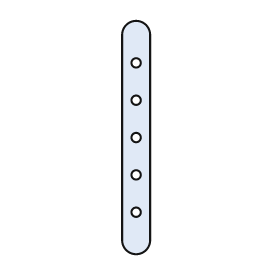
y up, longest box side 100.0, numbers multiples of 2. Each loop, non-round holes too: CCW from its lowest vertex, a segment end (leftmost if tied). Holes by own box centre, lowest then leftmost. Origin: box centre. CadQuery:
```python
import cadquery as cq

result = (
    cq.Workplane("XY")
    .moveTo(-6.0, -44.0)
    .threePointArc((0.0, -50.0), (6.0, -44.0))
    .lineTo(6.0, 44.0)
    .threePointArc((0.0, 50.0), (-6.0, 44.0))
    .close()
    .moveTo(0.0, -32.0)
    .circle(2.0)
    .moveTo(0.0, -16.0)
    .circle(2.0)
    .moveTo(0.0, 0.0)
    .circle(2.0)
    .moveTo(0.0, 16.0)
    .circle(2.0)
    .moveTo(0.0, 32.0)
    .circle(2.0)
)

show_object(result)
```